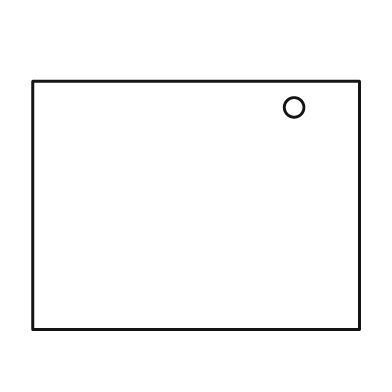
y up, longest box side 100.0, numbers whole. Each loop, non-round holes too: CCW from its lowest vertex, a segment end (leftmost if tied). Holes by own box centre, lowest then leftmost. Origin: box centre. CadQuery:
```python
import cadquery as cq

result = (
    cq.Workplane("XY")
    .moveTo(-50.0, -38.0)
    .lineTo(50.0, -38.0)
    .lineTo(50.0, 38.0)
    .lineTo(-50.0, 38.0)
    .close()
    .moveTo(30.0, 30.0)
    .circle(3.0)
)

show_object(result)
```